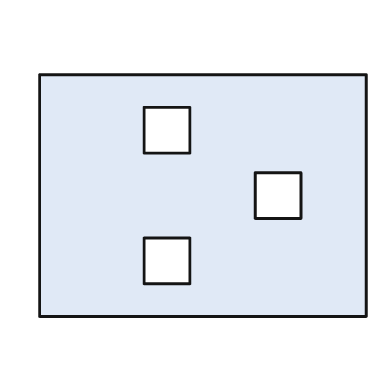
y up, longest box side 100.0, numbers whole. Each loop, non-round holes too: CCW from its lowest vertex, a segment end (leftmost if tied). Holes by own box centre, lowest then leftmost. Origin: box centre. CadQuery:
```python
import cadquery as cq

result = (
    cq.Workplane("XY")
    .moveTo(-50.0, -37.0)
    .lineTo(50.0, -37.0)
    .lineTo(50.0, 37.0)
    .lineTo(-50.0, 37.0)
    .close()
    .moveTo(-18.0, -27.0)
    .lineTo(-4.0, -27.0)
    .lineTo(-4.0, -13.0)
    .lineTo(-18.0, -13.0)
    .close()
    .moveTo(16.0, -7.0)
    .lineTo(30.0, -7.0)
    .lineTo(30.0, 7.0)
    .lineTo(16.0, 7.0)
    .close()
    .moveTo(-18.0, 13.0)
    .lineTo(-4.0, 13.0)
    .lineTo(-4.0, 27.0)
    .lineTo(-18.0, 27.0)
    .close()
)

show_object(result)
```